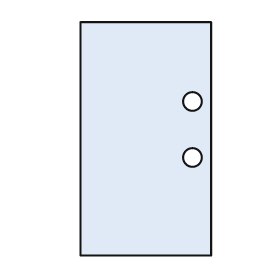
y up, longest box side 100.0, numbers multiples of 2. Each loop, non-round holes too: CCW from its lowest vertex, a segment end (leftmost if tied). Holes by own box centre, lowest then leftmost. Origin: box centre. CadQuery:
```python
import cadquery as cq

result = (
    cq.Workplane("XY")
    .moveTo(-28.0, -50.0)
    .lineTo(28.0, -50.0)
    .lineTo(28.0, 50.0)
    .lineTo(-28.0, 50.0)
    .close()
    .moveTo(20.0, -8.0)
    .circle(4.0)
    .moveTo(20.0, 16.0)
    .circle(4.0)
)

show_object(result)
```